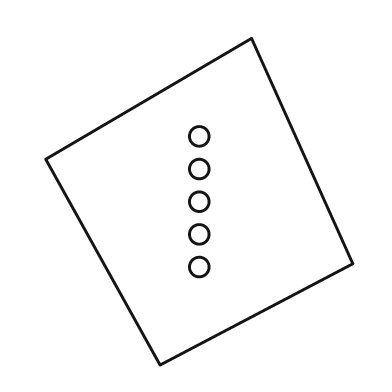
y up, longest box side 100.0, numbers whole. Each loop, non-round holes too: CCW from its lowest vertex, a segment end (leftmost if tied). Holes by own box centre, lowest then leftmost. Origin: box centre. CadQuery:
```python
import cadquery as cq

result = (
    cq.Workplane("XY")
    .moveTo(-12.0, -50.0)
    .lineTo(47.0, -19.0)
    .lineTo(16.0, 50.0)
    .lineTo(-47.0, 13.0)
    .close()
    .moveTo(0.0, -20.0)
    .circle(3.0)
    .moveTo(0.0, -10.0)
    .circle(3.0)
    .moveTo(0.0, 0.0)
    .circle(3.0)
    .moveTo(0.0, 10.0)
    .circle(3.0)
    .moveTo(0.0, 20.0)
    .circle(3.0)
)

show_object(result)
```